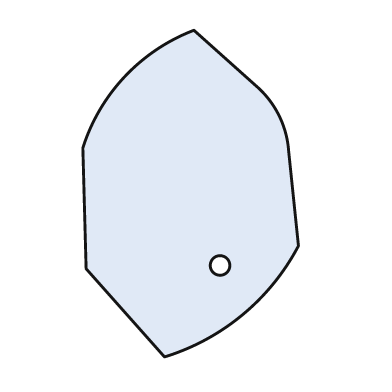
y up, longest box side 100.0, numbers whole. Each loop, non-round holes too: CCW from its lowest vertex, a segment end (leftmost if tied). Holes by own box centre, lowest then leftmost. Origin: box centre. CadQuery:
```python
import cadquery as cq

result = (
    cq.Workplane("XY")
    .moveTo(-8.0, -50.0)
    .threePointArc((16.0, -37.0), (33.0, -16.0))
    .lineTo(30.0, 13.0)
    .threePointArc((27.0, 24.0), (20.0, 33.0))
    .lineTo(1.0, 50.0)
    .threePointArc((-20.0, 36.0), (-33.0, 14.0))
    .lineTo(-32.0, -23.0)
    .close()
    .moveTo(9.0, -22.0)
    .circle(3.0)
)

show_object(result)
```